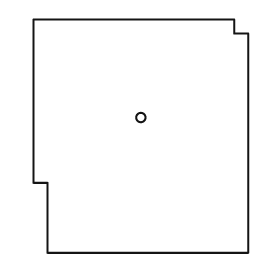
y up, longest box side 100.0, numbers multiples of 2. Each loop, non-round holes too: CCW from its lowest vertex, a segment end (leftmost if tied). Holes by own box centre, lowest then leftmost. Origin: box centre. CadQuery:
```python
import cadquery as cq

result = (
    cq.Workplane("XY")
    .moveTo(-40.0, -50.0)
    .lineTo(46.0, -50.0)
    .lineTo(46.0, 44.0)
    .lineTo(40.0, 44.0)
    .lineTo(40.0, 50.0)
    .lineTo(-46.0, 50.0)
    .lineTo(-46.0, -20.0)
    .lineTo(-40.0, -20.0)
    .close()
    .moveTo(0.0, 8.0)
    .circle(2.0)
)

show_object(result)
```